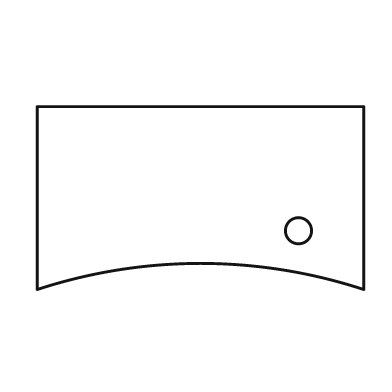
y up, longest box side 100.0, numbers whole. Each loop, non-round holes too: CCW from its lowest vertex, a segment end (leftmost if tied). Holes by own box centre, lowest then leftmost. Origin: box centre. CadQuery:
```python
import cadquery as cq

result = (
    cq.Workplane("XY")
    .moveTo(-50.0, -28.0)
    .threePointArc((0.0, -20.0), (50.0, -28.0))
    .lineTo(50.0, 28.0)
    .lineTo(-50.0, 28.0)
    .close()
    .moveTo(30.0, -10.0)
    .circle(4.0)
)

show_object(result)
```